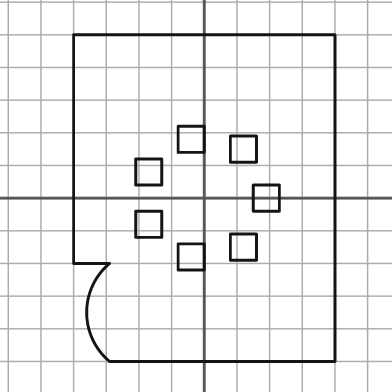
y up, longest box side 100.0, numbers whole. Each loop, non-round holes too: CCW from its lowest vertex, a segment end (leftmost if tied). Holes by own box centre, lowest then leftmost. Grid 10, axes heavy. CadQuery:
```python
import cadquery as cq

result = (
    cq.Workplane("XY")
    .moveTo(-29.0, -50.0)
    .lineTo(40.0, -50.0)
    .lineTo(40.0, 50.0)
    .lineTo(-40.0, 50.0)
    .lineTo(-40.0, -20.0)
    .lineTo(-29.0, -20.0)
    .threePointArc((-36.0, -35.0), (-29.0, -50.0))
    .close()
    .moveTo(-8.0, -22.0)
    .lineTo(0.0, -22.0)
    .lineTo(0.0, -14.0)
    .lineTo(-8.0, -14.0)
    .close()
    .moveTo(8.0, -19.0)
    .lineTo(16.0, -19.0)
    .lineTo(16.0, -11.0)
    .lineTo(8.0, -11.0)
    .close()
    .moveTo(-21.0, -12.0)
    .lineTo(-13.0, -12.0)
    .lineTo(-13.0, -4.0)
    .lineTo(-21.0, -4.0)
    .close()
    .moveTo(15.0, -4.0)
    .lineTo(23.0, -4.0)
    .lineTo(23.0, 4.0)
    .lineTo(15.0, 4.0)
    .close()
    .moveTo(-21.0, 4.0)
    .lineTo(-13.0, 4.0)
    .lineTo(-13.0, 12.0)
    .lineTo(-21.0, 12.0)
    .close()
    .moveTo(8.0, 11.0)
    .lineTo(16.0, 11.0)
    .lineTo(16.0, 19.0)
    .lineTo(8.0, 19.0)
    .close()
    .moveTo(-8.0, 14.0)
    .lineTo(0.0, 14.0)
    .lineTo(0.0, 22.0)
    .lineTo(-8.0, 22.0)
    .close()
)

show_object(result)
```